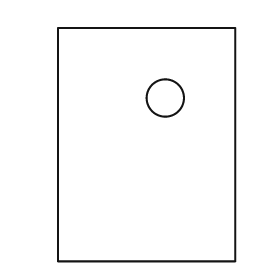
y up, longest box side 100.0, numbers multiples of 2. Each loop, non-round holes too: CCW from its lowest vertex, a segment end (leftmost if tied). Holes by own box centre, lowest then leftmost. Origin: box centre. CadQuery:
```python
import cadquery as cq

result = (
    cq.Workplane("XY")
    .moveTo(-38.0, -50.0)
    .lineTo(38.0, -50.0)
    .lineTo(38.0, 50.0)
    .lineTo(-38.0, 50.0)
    .close()
    .moveTo(8.0, 20.0)
    .circle(8.0)
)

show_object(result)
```